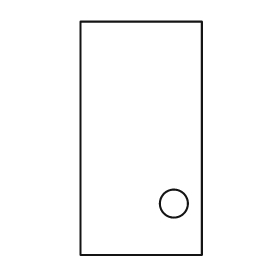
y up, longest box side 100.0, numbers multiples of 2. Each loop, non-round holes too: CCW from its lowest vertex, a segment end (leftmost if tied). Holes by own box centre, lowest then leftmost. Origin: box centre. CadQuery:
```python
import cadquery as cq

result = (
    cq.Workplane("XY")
    .moveTo(-26.0, -50.0)
    .lineTo(26.0, -50.0)
    .lineTo(26.0, 50.0)
    .lineTo(-26.0, 50.0)
    .close()
    .moveTo(14.0, -28.0)
    .circle(6.0)
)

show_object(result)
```